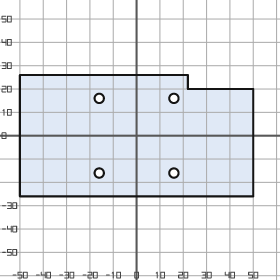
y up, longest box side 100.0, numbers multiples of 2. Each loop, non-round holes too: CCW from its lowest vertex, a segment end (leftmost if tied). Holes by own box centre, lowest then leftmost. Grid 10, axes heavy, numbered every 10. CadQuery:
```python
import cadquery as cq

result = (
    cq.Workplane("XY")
    .moveTo(-50.0, -26.0)
    .lineTo(50.0, -26.0)
    .lineTo(50.0, 20.0)
    .lineTo(22.0, 20.0)
    .lineTo(22.0, 26.0)
    .lineTo(-50.0, 26.0)
    .close()
    .moveTo(-16.0, -16.0)
    .circle(2.0)
    .moveTo(16.0, -16.0)
    .circle(2.0)
    .moveTo(-16.0, 16.0)
    .circle(2.0)
    .moveTo(16.0, 16.0)
    .circle(2.0)
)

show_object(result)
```